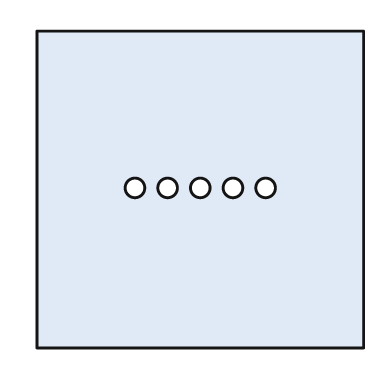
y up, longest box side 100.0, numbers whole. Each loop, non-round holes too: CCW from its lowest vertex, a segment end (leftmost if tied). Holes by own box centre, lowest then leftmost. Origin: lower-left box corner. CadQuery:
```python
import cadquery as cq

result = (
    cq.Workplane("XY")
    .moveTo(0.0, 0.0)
    .lineTo(100.0, 0.0)
    .lineTo(100.0, 97.0)
    .lineTo(0.0, 97.0)
    .close()
    .moveTo(30.0, 49.0)
    .circle(3.0)
    .moveTo(40.0, 49.0)
    .circle(3.0)
    .moveTo(50.0, 49.0)
    .circle(3.0)
    .moveTo(60.0, 49.0)
    .circle(3.0)
    .moveTo(70.0, 49.0)
    .circle(3.0)
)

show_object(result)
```